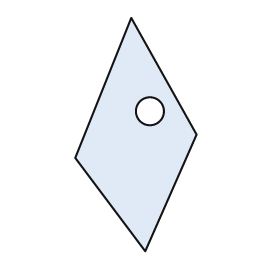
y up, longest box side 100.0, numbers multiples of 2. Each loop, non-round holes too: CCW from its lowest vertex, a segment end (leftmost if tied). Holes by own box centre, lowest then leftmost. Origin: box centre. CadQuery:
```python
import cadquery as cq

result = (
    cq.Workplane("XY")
    .moveTo(4.0, -50.0)
    .lineTo(26.0, 0.0)
    .lineTo(-2.0, 50.0)
    .lineTo(-26.0, -10.0)
    .close()
    .moveTo(6.0, 10.0)
    .circle(6.0)
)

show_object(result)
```